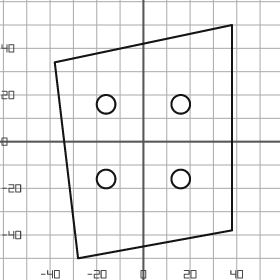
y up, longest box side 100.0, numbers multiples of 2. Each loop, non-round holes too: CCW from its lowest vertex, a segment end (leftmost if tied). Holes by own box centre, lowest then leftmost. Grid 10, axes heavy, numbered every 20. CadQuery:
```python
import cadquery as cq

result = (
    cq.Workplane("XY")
    .moveTo(-28.0, -50.0)
    .lineTo(38.0, -38.0)
    .lineTo(38.0, 50.0)
    .lineTo(-38.0, 34.0)
    .close()
    .moveTo(-16.0, -16.0)
    .circle(4.0)
    .moveTo(16.0, -16.0)
    .circle(4.0)
    .moveTo(-16.0, 16.0)
    .circle(4.0)
    .moveTo(16.0, 16.0)
    .circle(4.0)
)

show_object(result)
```